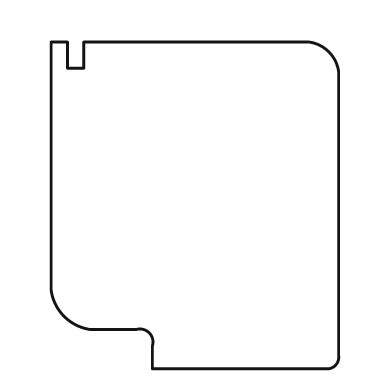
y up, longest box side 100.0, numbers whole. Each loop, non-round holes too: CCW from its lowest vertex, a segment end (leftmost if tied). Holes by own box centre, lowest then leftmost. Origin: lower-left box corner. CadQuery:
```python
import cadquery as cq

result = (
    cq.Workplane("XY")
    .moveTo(31.0, 0.0)
    .lineTo(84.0, 0.0)
    .threePointArc((87.0, 1.0), (88.0, 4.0))
    .lineTo(88.0, 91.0)
    .threePointArc((85.0, 97.0), (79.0, 100.0))
    .lineTo(10.0, 100.0)
    .lineTo(10.0, 92.0)
    .lineTo(5.0, 92.0)
    .lineTo(5.0, 100.0)
    .lineTo(0.0, 100.0)
    .lineTo(0.0, 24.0)
    .threePointArc((4.0, 16.0), (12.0, 12.0))
    .lineTo(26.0, 12.0)
    .threePointArc((30.0, 11.0), (31.0, 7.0))
    .close()
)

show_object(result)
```